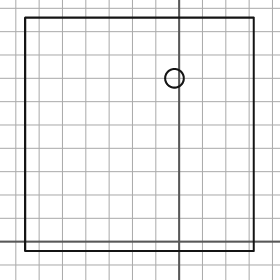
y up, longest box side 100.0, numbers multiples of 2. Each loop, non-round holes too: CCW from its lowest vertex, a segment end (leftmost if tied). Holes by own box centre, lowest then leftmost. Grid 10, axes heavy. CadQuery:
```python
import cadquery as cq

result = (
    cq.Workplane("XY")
    .moveTo(-66.0, -4.0)
    .lineTo(32.0, -4.0)
    .lineTo(32.0, 96.0)
    .lineTo(-66.0, 96.0)
    .close()
    .moveTo(-2.0, 70.0)
    .circle(4.0)
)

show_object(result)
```